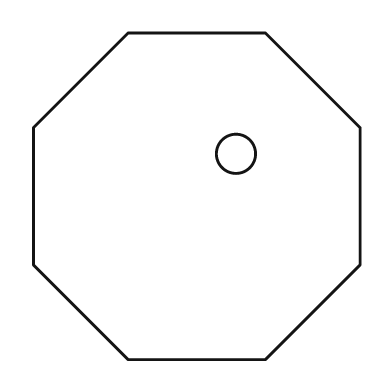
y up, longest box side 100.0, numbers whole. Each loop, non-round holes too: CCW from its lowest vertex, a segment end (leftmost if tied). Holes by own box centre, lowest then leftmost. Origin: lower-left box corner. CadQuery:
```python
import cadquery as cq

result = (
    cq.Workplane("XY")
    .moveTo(29.0, 0.0)
    .lineTo(71.0, 0.0)
    .lineTo(100.0, 29.0)
    .lineTo(100.0, 71.0)
    .lineTo(71.0, 100.0)
    .lineTo(29.0, 100.0)
    .lineTo(0.0, 71.0)
    .lineTo(0.0, 29.0)
    .close()
    .moveTo(62.0, 63.0)
    .circle(6.0)
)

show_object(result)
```